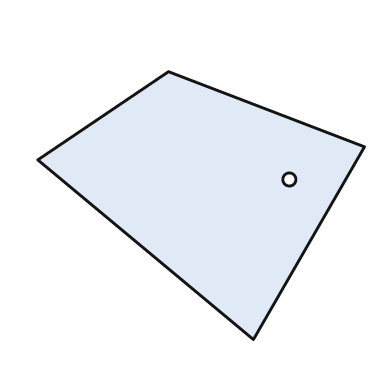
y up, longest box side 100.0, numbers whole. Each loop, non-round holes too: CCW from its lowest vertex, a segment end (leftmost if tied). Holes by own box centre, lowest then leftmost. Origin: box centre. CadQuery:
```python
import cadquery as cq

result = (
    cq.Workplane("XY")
    .moveTo(16.0, -41.0)
    .lineTo(50.0, 18.0)
    .lineTo(-10.0, 41.0)
    .lineTo(-50.0, 14.0)
    .close()
    .moveTo(27.0, 8.0)
    .circle(2.0)
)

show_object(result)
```